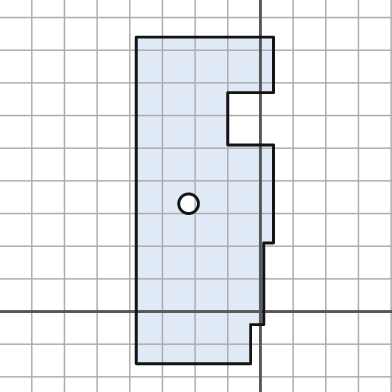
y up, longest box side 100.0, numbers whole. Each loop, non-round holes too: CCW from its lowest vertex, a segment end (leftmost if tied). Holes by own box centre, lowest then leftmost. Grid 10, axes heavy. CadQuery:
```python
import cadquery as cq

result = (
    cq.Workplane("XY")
    .moveTo(-38.0, -16.0)
    .lineTo(-3.0, -16.0)
    .lineTo(-3.0, -4.0)
    .lineTo(1.0, -4.0)
    .lineTo(1.0, 21.0)
    .lineTo(4.0, 21.0)
    .lineTo(4.0, 51.0)
    .lineTo(-10.0, 51.0)
    .lineTo(-10.0, 67.0)
    .lineTo(4.0, 67.0)
    .lineTo(4.0, 84.0)
    .lineTo(-38.0, 84.0)
    .close()
    .moveTo(-22.0, 33.0)
    .circle(3.0)
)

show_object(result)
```